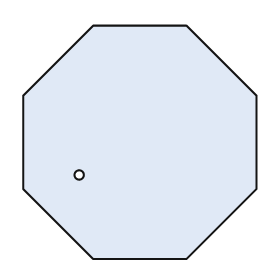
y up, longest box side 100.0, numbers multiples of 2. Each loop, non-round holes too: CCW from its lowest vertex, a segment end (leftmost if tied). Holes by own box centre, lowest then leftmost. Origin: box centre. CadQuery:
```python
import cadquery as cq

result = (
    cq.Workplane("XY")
    .moveTo(-20.0, -50.0)
    .lineTo(20.0, -50.0)
    .lineTo(50.0, -20.0)
    .lineTo(50.0, 20.0)
    .lineTo(20.0, 50.0)
    .lineTo(-20.0, 50.0)
    .lineTo(-50.0, 20.0)
    .lineTo(-50.0, -20.0)
    .close()
    .moveTo(-26.0, -14.0)
    .circle(2.0)
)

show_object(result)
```